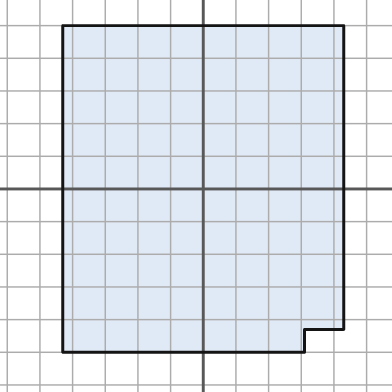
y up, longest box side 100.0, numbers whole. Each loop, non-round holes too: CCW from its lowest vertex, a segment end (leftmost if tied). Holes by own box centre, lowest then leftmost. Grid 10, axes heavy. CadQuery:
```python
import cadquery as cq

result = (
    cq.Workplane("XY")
    .moveTo(-43.0, -50.0)
    .lineTo(31.0, -50.0)
    .lineTo(31.0, -43.0)
    .lineTo(43.0, -43.0)
    .lineTo(43.0, 50.0)
    .lineTo(-43.0, 50.0)
    .close()
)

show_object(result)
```